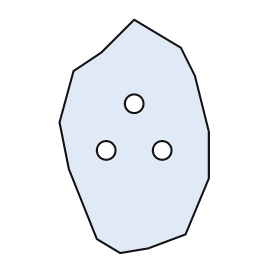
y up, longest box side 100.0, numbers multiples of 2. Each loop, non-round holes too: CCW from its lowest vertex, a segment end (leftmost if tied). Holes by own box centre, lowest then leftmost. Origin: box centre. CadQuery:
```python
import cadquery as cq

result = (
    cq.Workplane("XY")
    .moveTo(-6.0, -50.0)
    .lineTo(6.0, -48.0)
    .lineTo(22.0, -42.0)
    .lineTo(32.0, -18.0)
    .lineTo(32.0, 2.0)
    .lineTo(26.0, 26.0)
    .lineTo(20.0, 38.0)
    .lineTo(0.0, 50.0)
    .lineTo(-14.0, 36.0)
    .lineTo(-26.0, 28.0)
    .lineTo(-32.0, 6.0)
    .lineTo(-28.0, -14.0)
    .lineTo(-16.0, -44.0)
    .close()
    .moveTo(-12.0, -6.0)
    .circle(4.0)
    .moveTo(12.0, -6.0)
    .circle(4.0)
    .moveTo(0.0, 14.0)
    .circle(4.0)
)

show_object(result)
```